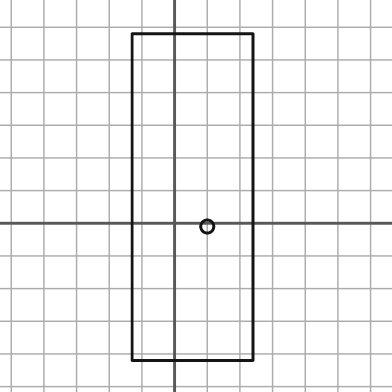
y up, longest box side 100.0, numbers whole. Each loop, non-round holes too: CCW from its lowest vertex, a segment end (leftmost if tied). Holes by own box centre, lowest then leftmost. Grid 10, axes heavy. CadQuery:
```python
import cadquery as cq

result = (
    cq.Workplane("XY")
    .moveTo(-13.0, -42.0)
    .lineTo(24.0, -42.0)
    .lineTo(24.0, 58.0)
    .lineTo(-13.0, 58.0)
    .close()
    .moveTo(10.0, -1.0)
    .circle(2.0)
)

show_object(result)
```